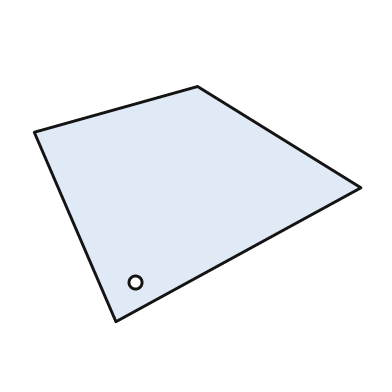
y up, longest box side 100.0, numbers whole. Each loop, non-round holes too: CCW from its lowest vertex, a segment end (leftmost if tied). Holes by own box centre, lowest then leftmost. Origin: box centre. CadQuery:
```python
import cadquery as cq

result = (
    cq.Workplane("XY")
    .moveTo(-25.0, -36.0)
    .lineTo(50.0, 5.0)
    .lineTo(0.0, 36.0)
    .lineTo(-50.0, 22.0)
    .close()
    .moveTo(-19.0, -24.0)
    .circle(2.0)
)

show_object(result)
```